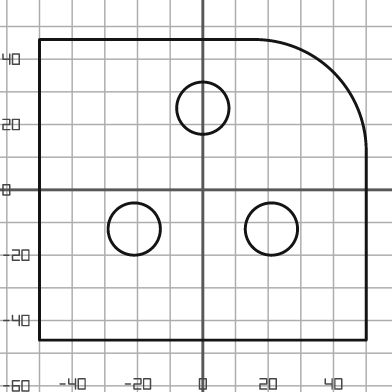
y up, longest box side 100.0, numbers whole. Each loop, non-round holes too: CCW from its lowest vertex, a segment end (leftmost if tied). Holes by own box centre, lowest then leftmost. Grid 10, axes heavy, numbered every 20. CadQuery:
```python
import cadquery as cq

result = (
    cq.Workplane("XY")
    .moveTo(-50.0, -46.0)
    .lineTo(50.0, -46.0)
    .lineTo(50.0, 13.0)
    .threePointArc((40.0, 36.0), (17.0, 46.0))
    .lineTo(-50.0, 46.0)
    .close()
    .moveTo(-21.0, -12.0)
    .circle(8.0)
    .moveTo(21.0, -12.0)
    .circle(8.0)
    .moveTo(0.0, 25.0)
    .circle(8.0)
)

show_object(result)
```